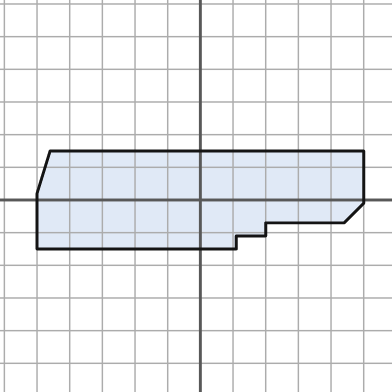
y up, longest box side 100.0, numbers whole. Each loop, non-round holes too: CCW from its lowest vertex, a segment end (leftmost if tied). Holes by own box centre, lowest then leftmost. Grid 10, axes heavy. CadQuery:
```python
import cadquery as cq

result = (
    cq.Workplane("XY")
    .moveTo(-50.0, -15.0)
    .lineTo(11.0, -15.0)
    .lineTo(11.0, -11.0)
    .lineTo(20.0, -11.0)
    .lineTo(20.0, -7.0)
    .lineTo(44.0, -7.0)
    .lineTo(50.0, -1.0)
    .lineTo(50.0, 15.0)
    .lineTo(-46.0, 15.0)
    .lineTo(-50.0, 2.0)
    .close()
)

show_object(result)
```